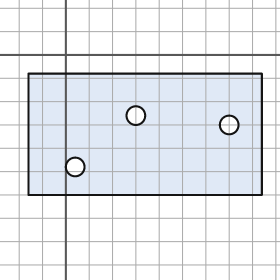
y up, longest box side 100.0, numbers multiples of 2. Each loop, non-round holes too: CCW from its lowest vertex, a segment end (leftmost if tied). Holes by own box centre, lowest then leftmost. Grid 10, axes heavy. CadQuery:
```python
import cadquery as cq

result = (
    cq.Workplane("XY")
    .moveTo(-16.0, -60.0)
    .lineTo(84.0, -60.0)
    .lineTo(84.0, -8.0)
    .lineTo(-16.0, -8.0)
    .close()
    .moveTo(4.0, -48.0)
    .circle(4.0)
    .moveTo(70.0, -30.0)
    .circle(4.0)
    .moveTo(30.0, -26.0)
    .circle(4.0)
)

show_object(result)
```